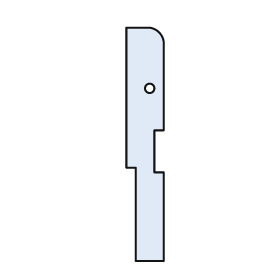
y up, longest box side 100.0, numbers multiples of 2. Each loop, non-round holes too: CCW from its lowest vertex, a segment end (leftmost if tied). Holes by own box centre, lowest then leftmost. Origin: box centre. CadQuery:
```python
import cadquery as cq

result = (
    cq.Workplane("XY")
    .moveTo(-4.0, -50.0)
    .lineTo(8.0, -50.0)
    .lineTo(8.0, -12.0)
    .lineTo(4.0, -12.0)
    .lineTo(4.0, 6.0)
    .lineTo(8.0, 6.0)
    .lineTo(8.0, 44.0)
    .threePointArc((6.0, 48.0), (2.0, 50.0))
    .lineTo(-8.0, 50.0)
    .lineTo(-8.0, -10.0)
    .lineTo(-4.0, -10.0)
    .close()
    .moveTo(2.0, 24.0)
    .circle(2.0)
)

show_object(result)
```